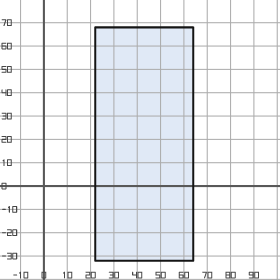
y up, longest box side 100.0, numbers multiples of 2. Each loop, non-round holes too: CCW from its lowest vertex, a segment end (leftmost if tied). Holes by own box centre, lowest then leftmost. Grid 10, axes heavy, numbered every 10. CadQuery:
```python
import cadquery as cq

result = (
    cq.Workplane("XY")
    .moveTo(22.0, -32.0)
    .lineTo(64.0, -32.0)
    .lineTo(64.0, 68.0)
    .lineTo(22.0, 68.0)
    .close()
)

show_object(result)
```